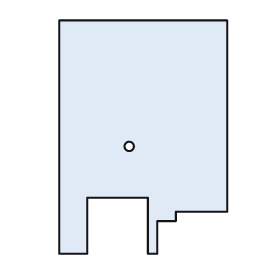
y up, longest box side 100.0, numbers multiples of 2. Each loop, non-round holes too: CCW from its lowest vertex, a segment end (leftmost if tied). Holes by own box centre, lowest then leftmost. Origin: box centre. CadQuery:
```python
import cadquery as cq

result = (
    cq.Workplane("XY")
    .moveTo(-36.0, -50.0)
    .lineTo(-24.0, -50.0)
    .lineTo(-24.0, -26.0)
    .lineTo(2.0, -26.0)
    .lineTo(2.0, -50.0)
    .lineTo(6.0, -50.0)
    .lineTo(6.0, -36.0)
    .lineTo(14.0, -36.0)
    .lineTo(14.0, -32.0)
    .lineTo(36.0, -32.0)
    .lineTo(36.0, 50.0)
    .lineTo(-36.0, 50.0)
    .close()
    .moveTo(-6.0, -4.0)
    .circle(2.0)
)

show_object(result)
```